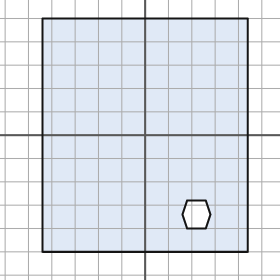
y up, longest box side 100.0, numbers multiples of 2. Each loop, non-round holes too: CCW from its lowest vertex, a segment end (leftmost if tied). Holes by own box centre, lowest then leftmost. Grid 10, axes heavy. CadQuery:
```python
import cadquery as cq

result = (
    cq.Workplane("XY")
    .moveTo(-44.0, -50.0)
    .lineTo(44.0, -50.0)
    .lineTo(44.0, 50.0)
    .lineTo(-44.0, 50.0)
    .close()
    .moveTo(18.0, -40.0)
    .lineTo(26.0, -40.0)
    .lineTo(28.0, -34.0)
    .lineTo(26.0, -28.0)
    .lineTo(18.0, -28.0)
    .lineTo(16.0, -34.0)
    .close()
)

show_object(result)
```